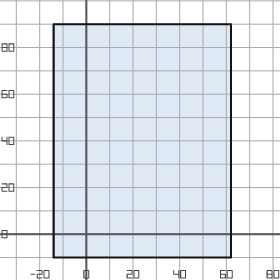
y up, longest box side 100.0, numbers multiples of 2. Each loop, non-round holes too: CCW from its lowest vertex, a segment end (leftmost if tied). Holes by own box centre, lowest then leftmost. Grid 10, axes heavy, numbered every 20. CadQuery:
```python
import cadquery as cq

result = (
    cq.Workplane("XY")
    .moveTo(-14.0, -10.0)
    .lineTo(62.0, -10.0)
    .lineTo(62.0, 90.0)
    .lineTo(-14.0, 90.0)
    .close()
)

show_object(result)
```